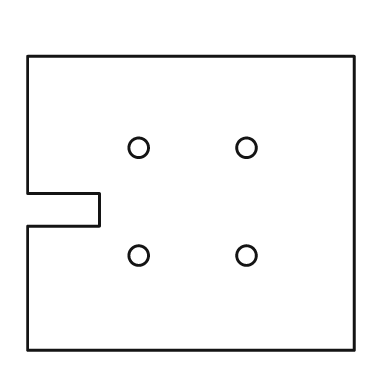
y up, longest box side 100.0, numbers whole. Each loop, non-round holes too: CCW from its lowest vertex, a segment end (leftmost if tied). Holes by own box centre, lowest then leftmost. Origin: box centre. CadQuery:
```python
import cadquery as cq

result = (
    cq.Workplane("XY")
    .moveTo(-50.0, -45.0)
    .lineTo(50.0, -45.0)
    .lineTo(50.0, 45.0)
    .lineTo(-50.0, 45.0)
    .lineTo(-50.0, 3.0)
    .lineTo(-28.0, 3.0)
    .lineTo(-28.0, -7.0)
    .lineTo(-50.0, -7.0)
    .close()
    .moveTo(-16.0, -16.0)
    .circle(3.0)
    .moveTo(17.0, -16.0)
    .circle(3.0)
    .moveTo(-16.0, 17.0)
    .circle(3.0)
    .moveTo(17.0, 17.0)
    .circle(3.0)
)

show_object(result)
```